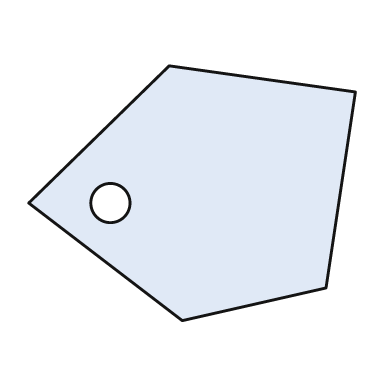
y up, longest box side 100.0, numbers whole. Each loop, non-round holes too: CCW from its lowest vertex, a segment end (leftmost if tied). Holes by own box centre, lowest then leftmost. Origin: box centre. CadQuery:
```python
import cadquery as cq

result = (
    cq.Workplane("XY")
    .moveTo(-3.0, -39.0)
    .lineTo(41.0, -29.0)
    .lineTo(50.0, 31.0)
    .lineTo(-7.0, 39.0)
    .lineTo(-50.0, -3.0)
    .close()
    .moveTo(-25.0, -3.0)
    .circle(6.0)
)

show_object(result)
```